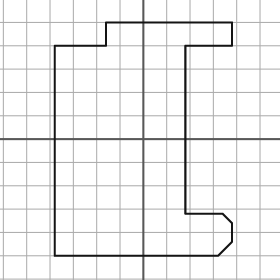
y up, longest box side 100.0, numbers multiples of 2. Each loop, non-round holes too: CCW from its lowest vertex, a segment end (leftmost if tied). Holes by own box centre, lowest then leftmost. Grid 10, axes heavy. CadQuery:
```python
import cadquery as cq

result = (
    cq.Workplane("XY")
    .moveTo(-38.0, -50.0)
    .lineTo(32.0, -50.0)
    .lineTo(38.0, -44.0)
    .lineTo(38.0, -36.0)
    .lineTo(34.0, -32.0)
    .lineTo(18.0, -32.0)
    .lineTo(18.0, 40.0)
    .lineTo(38.0, 40.0)
    .lineTo(38.0, 50.0)
    .lineTo(-16.0, 50.0)
    .lineTo(-16.0, 40.0)
    .lineTo(-38.0, 40.0)
    .close()
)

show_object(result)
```